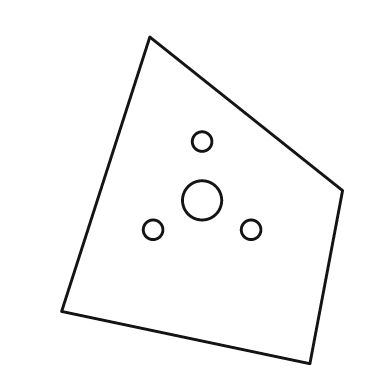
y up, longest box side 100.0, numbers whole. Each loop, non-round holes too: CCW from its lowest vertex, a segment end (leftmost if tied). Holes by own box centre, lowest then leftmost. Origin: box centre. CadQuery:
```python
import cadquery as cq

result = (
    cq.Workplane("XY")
    .moveTo(33.0, -50.0)
    .lineTo(43.0, 3.0)
    .lineTo(-16.0, 50.0)
    .lineTo(-43.0, -34.0)
    .close()
    .moveTo(-15.0, -9.0)
    .circle(3.0)
    .moveTo(15.0, -9.0)
    .circle(3.0)
    .moveTo(0.0, 0.0)
    .circle(6.0)
    .moveTo(0.0, 18.0)
    .circle(3.0)
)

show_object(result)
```